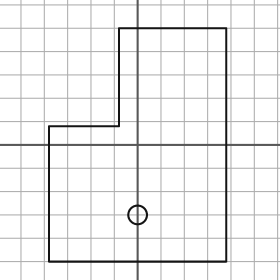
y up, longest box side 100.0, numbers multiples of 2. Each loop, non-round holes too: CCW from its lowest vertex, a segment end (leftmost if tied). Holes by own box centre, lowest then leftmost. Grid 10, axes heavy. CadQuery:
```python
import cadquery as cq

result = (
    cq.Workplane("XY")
    .moveTo(-38.0, -50.0)
    .lineTo(38.0, -50.0)
    .lineTo(38.0, 50.0)
    .lineTo(-8.0, 50.0)
    .lineTo(-8.0, 8.0)
    .lineTo(-38.0, 8.0)
    .close()
    .moveTo(0.0, -30.0)
    .circle(4.0)
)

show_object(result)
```